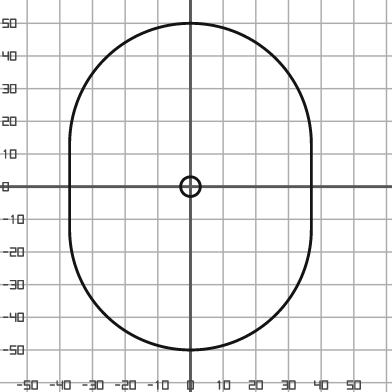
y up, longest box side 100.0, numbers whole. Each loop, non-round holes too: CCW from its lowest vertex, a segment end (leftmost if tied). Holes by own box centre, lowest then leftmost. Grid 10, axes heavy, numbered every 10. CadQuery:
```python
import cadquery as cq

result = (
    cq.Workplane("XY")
    .moveTo(-37.0, -13.0)
    .threePointArc((0.0, -50.0), (37.0, -13.0))
    .lineTo(37.0, 13.0)
    .threePointArc((0.0, 50.0), (-37.0, 13.0))
    .close()
    .moveTo(0.0, 0.0)
    .circle(3.0)
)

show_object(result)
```